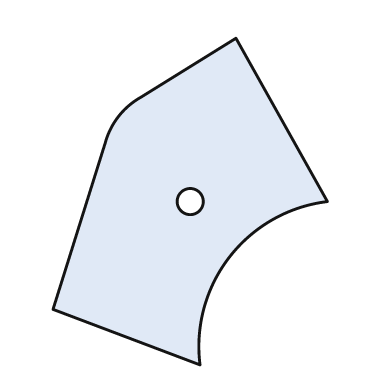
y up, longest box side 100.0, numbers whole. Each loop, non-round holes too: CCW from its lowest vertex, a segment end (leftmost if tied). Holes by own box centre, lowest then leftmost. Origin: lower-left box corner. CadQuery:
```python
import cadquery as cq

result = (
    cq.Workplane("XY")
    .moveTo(45.0, 0.0)
    .threePointArc((54.0, 33.0), (84.0, 50.0))
    .lineTo(56.0, 100.0)
    .lineTo(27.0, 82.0)
    .threePointArc((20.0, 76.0), (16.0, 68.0))
    .lineTo(0.0, 17.0)
    .close()
    .moveTo(42.0, 50.0)
    .circle(4.0)
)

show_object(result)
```